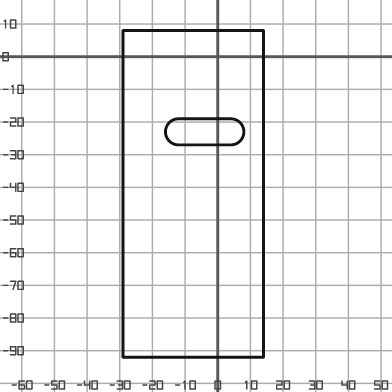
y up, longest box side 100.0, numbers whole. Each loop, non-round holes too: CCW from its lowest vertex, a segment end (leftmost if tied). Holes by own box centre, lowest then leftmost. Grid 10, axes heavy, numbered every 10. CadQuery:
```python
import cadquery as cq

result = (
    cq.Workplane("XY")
    .moveTo(-29.0, -92.0)
    .lineTo(14.0, -92.0)
    .lineTo(14.0, 8.0)
    .lineTo(-29.0, 8.0)
    .close()
    .moveTo(-12.0, -27.0)
    .lineTo(4.0, -27.0)
    .threePointArc((8.0, -23.0), (4.0, -19.0))
    .lineTo(-12.0, -19.0)
    .threePointArc((-16.0, -23.0), (-12.0, -27.0))
    .close()
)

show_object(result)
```